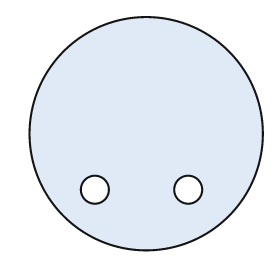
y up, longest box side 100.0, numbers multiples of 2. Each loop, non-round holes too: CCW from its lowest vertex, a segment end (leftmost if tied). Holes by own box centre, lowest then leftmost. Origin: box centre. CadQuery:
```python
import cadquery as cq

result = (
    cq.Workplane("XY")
    .moveTo(0.0, 0.0)
    .circle(50.0)
    .moveTo(-22.0, -24.0)
    .circle(6.0)
    .moveTo(18.0, -24.0)
    .circle(6.0)
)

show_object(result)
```